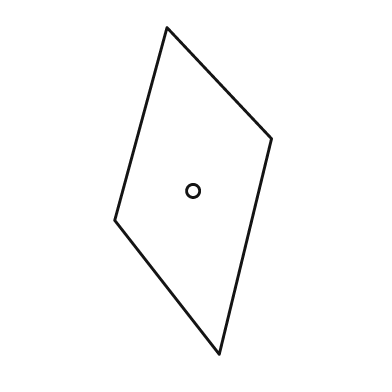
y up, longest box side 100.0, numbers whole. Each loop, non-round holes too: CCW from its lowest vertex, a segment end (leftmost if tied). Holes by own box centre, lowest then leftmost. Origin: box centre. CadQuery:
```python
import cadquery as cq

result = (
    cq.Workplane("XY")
    .moveTo(8.0, -50.0)
    .lineTo(24.0, 16.0)
    .lineTo(-8.0, 50.0)
    .lineTo(-24.0, -9.0)
    .close()
    .moveTo(0.0, 0.0)
    .circle(2.0)
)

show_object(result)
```